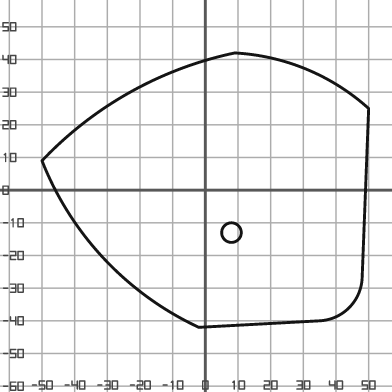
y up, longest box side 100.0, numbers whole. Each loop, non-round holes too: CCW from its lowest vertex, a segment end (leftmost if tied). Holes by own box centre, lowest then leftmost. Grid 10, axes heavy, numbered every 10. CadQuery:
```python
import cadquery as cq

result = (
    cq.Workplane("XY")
    .moveTo(-2.0, -42.0)
    .lineTo(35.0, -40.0)
    .threePointArc((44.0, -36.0), (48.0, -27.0))
    .lineTo(50.0, 25.0)
    .threePointArc((31.0, 37.0), (9.0, 42.0))
    .threePointArc((-23.0, 30.0), (-50.0, 9.0))
    .threePointArc((-31.0, -21.0), (-2.0, -42.0))
    .close()
    .moveTo(8.0, -13.0)
    .circle(3.0)
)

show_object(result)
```